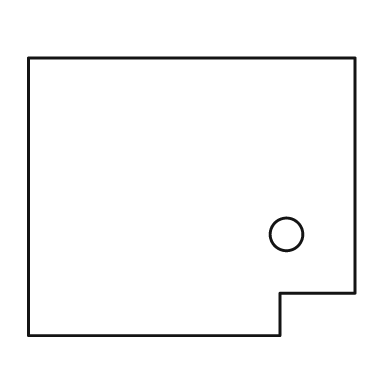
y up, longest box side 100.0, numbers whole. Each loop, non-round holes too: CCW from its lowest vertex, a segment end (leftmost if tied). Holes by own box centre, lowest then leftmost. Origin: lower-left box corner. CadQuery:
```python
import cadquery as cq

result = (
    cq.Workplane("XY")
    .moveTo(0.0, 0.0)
    .lineTo(77.0, 0.0)
    .lineTo(77.0, 13.0)
    .lineTo(100.0, 13.0)
    .lineTo(100.0, 85.0)
    .lineTo(0.0, 85.0)
    .close()
    .moveTo(79.0, 31.0)
    .circle(5.0)
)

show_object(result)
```